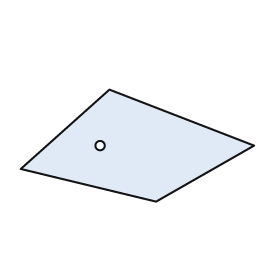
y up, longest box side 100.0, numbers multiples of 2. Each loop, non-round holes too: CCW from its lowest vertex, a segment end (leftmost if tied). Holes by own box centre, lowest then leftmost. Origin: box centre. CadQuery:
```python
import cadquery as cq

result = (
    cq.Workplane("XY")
    .moveTo(8.0, -24.0)
    .lineTo(50.0, 0.0)
    .lineTo(-12.0, 24.0)
    .lineTo(-50.0, -10.0)
    .close()
    .moveTo(-16.0, 0.0)
    .circle(2.0)
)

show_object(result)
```